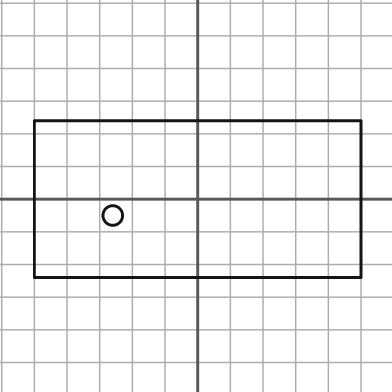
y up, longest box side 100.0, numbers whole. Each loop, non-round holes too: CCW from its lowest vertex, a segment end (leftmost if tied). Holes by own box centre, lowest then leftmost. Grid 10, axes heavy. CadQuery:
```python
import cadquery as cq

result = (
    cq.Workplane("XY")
    .moveTo(-50.0, -24.0)
    .lineTo(50.0, -24.0)
    .lineTo(50.0, 24.0)
    .lineTo(-50.0, 24.0)
    .close()
    .moveTo(-26.0, -5.0)
    .circle(3.0)
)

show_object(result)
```